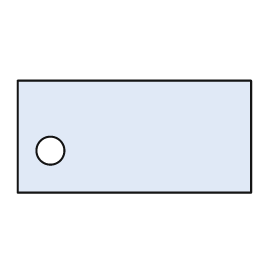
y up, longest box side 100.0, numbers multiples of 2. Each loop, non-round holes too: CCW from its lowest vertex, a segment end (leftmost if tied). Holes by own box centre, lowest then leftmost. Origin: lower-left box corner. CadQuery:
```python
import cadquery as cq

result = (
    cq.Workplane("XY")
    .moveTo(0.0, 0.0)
    .lineTo(100.0, 0.0)
    .lineTo(100.0, 48.0)
    .lineTo(0.0, 48.0)
    .close()
    .moveTo(14.0, 18.0)
    .circle(6.0)
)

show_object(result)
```